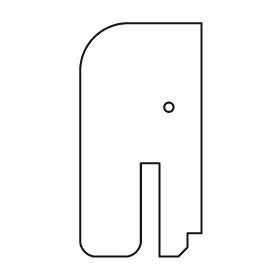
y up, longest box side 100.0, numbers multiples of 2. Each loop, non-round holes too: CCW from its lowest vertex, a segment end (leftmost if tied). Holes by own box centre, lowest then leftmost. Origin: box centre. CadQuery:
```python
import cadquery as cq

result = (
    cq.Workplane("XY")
    .moveTo(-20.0, -50.0)
    .lineTo(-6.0, -50.0)
    .threePointArc((-2.0, -48.0), (0.0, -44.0))
    .lineTo(0.0, -10.0)
    .lineTo(8.0, -10.0)
    .lineTo(8.0, -50.0)
    .lineTo(16.0, -50.0)
    .lineTo(20.0, -46.0)
    .lineTo(20.0, -40.0)
    .lineTo(26.0, -40.0)
    .lineTo(26.0, 50.0)
    .lineTo(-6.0, 50.0)
    .threePointArc((-20.0, 44.0), (-26.0, 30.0))
    .lineTo(-26.0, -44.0)
    .threePointArc((-24.0, -48.0), (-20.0, -50.0))
    .close()
    .moveTo(12.0, 14.0)
    .circle(2.0)
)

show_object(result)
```